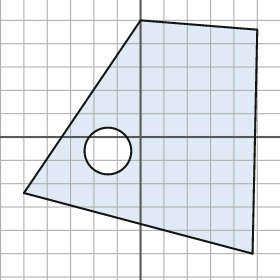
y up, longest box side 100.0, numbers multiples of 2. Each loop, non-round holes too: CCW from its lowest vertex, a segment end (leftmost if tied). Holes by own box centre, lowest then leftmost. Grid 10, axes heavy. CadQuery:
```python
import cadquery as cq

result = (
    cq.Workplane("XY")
    .moveTo(48.0, -50.0)
    .lineTo(50.0, 46.0)
    .lineTo(0.0, 50.0)
    .lineTo(-50.0, -24.0)
    .close()
    .moveTo(-14.0, -6.0)
    .circle(10.0)
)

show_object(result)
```